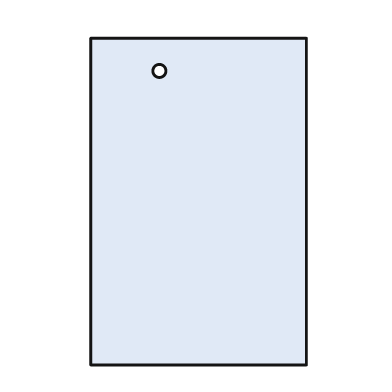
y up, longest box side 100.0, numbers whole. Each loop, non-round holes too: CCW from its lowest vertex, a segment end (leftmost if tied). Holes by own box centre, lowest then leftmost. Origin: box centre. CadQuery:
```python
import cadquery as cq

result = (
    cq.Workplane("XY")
    .moveTo(-33.0, -50.0)
    .lineTo(33.0, -50.0)
    .lineTo(33.0, 50.0)
    .lineTo(-33.0, 50.0)
    .close()
    .moveTo(-12.0, 40.0)
    .circle(2.0)
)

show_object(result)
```